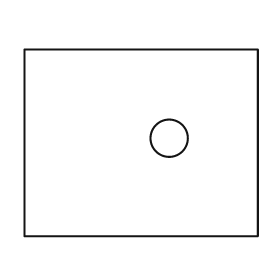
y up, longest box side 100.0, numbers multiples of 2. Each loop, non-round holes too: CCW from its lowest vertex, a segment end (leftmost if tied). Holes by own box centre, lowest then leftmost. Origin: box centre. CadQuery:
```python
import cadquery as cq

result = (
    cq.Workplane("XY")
    .moveTo(-50.0, -40.0)
    .lineTo(50.0, -40.0)
    .lineTo(50.0, 40.0)
    .lineTo(-50.0, 40.0)
    .close()
    .moveTo(12.0, 2.0)
    .circle(8.0)
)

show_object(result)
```